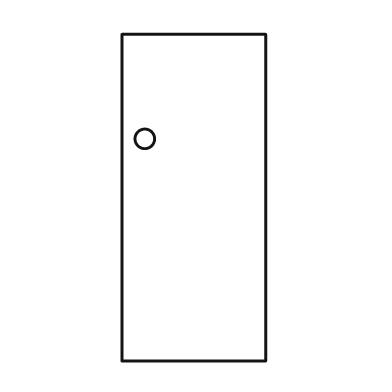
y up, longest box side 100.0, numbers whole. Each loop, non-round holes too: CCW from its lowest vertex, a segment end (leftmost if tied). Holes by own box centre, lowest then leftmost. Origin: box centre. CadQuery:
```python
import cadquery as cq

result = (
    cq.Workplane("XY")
    .moveTo(-22.0, -50.0)
    .lineTo(22.0, -50.0)
    .lineTo(22.0, 50.0)
    .lineTo(-22.0, 50.0)
    .close()
    .moveTo(-15.0, 18.0)
    .circle(3.0)
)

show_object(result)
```